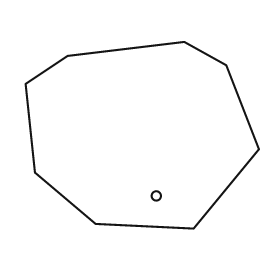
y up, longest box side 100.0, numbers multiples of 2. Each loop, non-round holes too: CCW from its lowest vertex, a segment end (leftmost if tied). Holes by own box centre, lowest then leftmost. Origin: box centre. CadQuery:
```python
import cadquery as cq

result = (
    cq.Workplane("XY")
    .moveTo(22.0, -40.0)
    .lineTo(50.0, -6.0)
    .lineTo(36.0, 30.0)
    .lineTo(18.0, 40.0)
    .lineTo(-32.0, 34.0)
    .lineTo(-50.0, 22.0)
    .lineTo(-46.0, -16.0)
    .lineTo(-20.0, -38.0)
    .close()
    .moveTo(6.0, -26.0)
    .circle(2.0)
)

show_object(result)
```